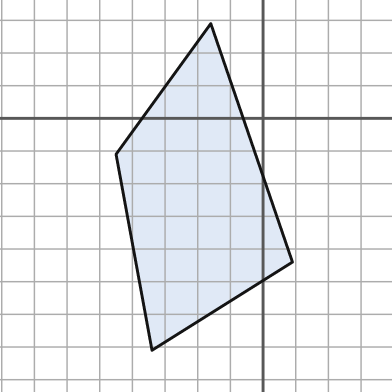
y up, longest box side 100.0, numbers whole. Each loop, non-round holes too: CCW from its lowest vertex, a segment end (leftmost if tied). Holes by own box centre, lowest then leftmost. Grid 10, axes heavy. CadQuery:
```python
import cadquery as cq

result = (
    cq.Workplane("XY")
    .moveTo(-34.0, -71.0)
    .lineTo(9.0, -44.0)
    .lineTo(-16.0, 29.0)
    .lineTo(-45.0, -11.0)
    .close()
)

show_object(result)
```